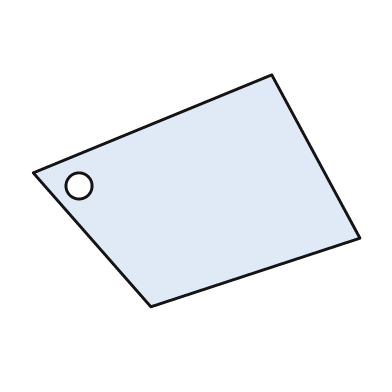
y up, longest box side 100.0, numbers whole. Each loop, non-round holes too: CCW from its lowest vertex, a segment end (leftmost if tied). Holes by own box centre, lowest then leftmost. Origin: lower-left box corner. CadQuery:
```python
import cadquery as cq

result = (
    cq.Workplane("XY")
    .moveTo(36.0, 0.0)
    .lineTo(100.0, 21.0)
    .lineTo(73.0, 71.0)
    .lineTo(0.0, 41.0)
    .close()
    .moveTo(14.0, 37.0)
    .circle(4.0)
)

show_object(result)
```